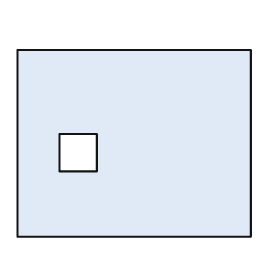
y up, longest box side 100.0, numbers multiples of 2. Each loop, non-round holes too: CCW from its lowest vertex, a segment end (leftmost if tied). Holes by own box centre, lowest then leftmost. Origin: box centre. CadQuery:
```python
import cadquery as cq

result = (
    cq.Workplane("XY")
    .moveTo(-50.0, -40.0)
    .lineTo(50.0, -40.0)
    .lineTo(50.0, 40.0)
    .lineTo(-50.0, 40.0)
    .close()
    .moveTo(-32.0, -12.0)
    .lineTo(-16.0, -12.0)
    .lineTo(-16.0, 4.0)
    .lineTo(-32.0, 4.0)
    .close()
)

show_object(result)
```